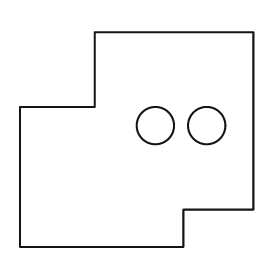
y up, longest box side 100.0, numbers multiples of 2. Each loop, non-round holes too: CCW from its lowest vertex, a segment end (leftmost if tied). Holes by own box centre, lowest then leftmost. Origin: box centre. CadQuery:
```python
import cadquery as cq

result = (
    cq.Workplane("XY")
    .moveTo(-50.0, -46.0)
    .lineTo(20.0, -46.0)
    .lineTo(20.0, -30.0)
    .lineTo(50.0, -30.0)
    .lineTo(50.0, 46.0)
    .lineTo(-18.0, 46.0)
    .lineTo(-18.0, 14.0)
    .lineTo(-50.0, 14.0)
    .close()
    .moveTo(8.0, 6.0)
    .circle(8.0)
    .moveTo(30.0, 6.0)
    .circle(8.0)
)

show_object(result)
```